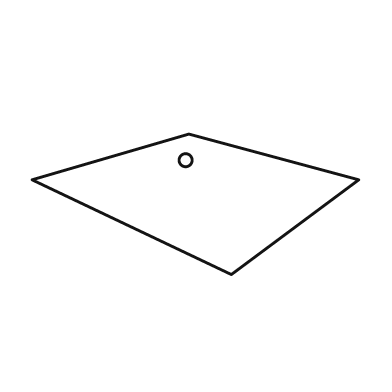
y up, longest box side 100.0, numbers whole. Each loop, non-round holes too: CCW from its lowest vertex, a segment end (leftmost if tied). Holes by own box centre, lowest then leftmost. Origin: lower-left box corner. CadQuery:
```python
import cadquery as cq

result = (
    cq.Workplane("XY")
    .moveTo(61.0, 0.0)
    .lineTo(100.0, 29.0)
    .lineTo(48.0, 43.0)
    .lineTo(0.0, 29.0)
    .close()
    .moveTo(47.0, 35.0)
    .circle(2.0)
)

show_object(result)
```